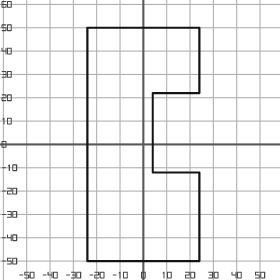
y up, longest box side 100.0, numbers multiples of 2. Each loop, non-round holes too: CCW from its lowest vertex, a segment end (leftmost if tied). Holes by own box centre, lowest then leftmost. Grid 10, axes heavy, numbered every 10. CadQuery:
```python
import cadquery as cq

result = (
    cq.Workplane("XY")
    .moveTo(-24.0, -50.0)
    .lineTo(24.0, -50.0)
    .lineTo(24.0, -12.0)
    .lineTo(4.0, -12.0)
    .lineTo(4.0, 22.0)
    .lineTo(24.0, 22.0)
    .lineTo(24.0, 50.0)
    .lineTo(-24.0, 50.0)
    .close()
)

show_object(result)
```